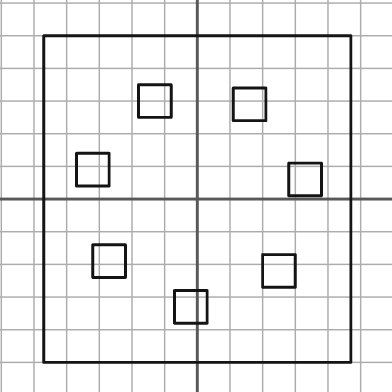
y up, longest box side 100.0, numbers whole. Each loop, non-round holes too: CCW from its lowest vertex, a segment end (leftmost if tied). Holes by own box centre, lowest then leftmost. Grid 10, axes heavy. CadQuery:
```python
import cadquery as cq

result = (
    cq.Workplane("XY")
    .moveTo(-47.0, -50.0)
    .lineTo(47.0, -50.0)
    .lineTo(47.0, 50.0)
    .lineTo(-47.0, 50.0)
    .close()
    .moveTo(-7.0, -38.0)
    .lineTo(3.0, -38.0)
    .lineTo(3.0, -28.0)
    .lineTo(-7.0, -28.0)
    .close()
    .moveTo(20.0, -27.0)
    .lineTo(30.0, -27.0)
    .lineTo(30.0, -17.0)
    .lineTo(20.0, -17.0)
    .close()
    .moveTo(-32.0, -24.0)
    .lineTo(-22.0, -24.0)
    .lineTo(-22.0, -14.0)
    .lineTo(-32.0, -14.0)
    .close()
    .moveTo(28.0, 1.0)
    .lineTo(38.0, 1.0)
    .lineTo(38.0, 11.0)
    .lineTo(28.0, 11.0)
    .close()
    .moveTo(-37.0, 4.0)
    .lineTo(-27.0, 4.0)
    .lineTo(-27.0, 14.0)
    .lineTo(-37.0, 14.0)
    .close()
    .moveTo(11.0, 24.0)
    .lineTo(21.0, 24.0)
    .lineTo(21.0, 34.0)
    .lineTo(11.0, 34.0)
    .close()
    .moveTo(-18.0, 25.0)
    .lineTo(-8.0, 25.0)
    .lineTo(-8.0, 35.0)
    .lineTo(-18.0, 35.0)
    .close()
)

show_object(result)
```